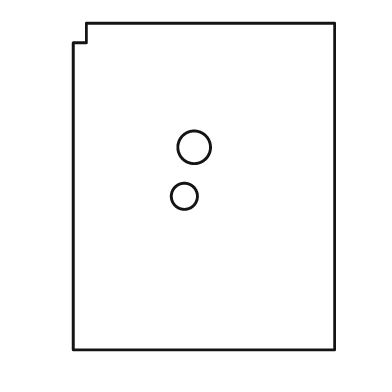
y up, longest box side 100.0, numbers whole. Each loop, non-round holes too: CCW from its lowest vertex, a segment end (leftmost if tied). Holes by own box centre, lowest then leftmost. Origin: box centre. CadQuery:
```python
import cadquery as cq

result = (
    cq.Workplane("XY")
    .moveTo(-40.0, -50.0)
    .lineTo(40.0, -50.0)
    .lineTo(40.0, 50.0)
    .lineTo(-36.0, 50.0)
    .lineTo(-36.0, 44.0)
    .lineTo(-40.0, 44.0)
    .close()
    .moveTo(-6.0, -3.0)
    .circle(4.0)
    .moveTo(-3.0, 12.0)
    .circle(5.0)
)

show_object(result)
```